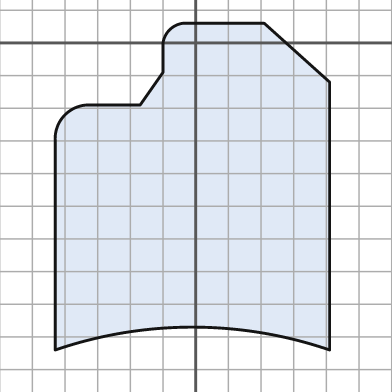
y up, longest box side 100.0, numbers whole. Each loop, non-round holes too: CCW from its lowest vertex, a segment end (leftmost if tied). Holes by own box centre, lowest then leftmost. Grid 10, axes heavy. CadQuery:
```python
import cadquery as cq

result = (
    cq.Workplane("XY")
    .moveTo(-43.0, -94.0)
    .threePointArc((-1.0, -87.0), (41.0, -94.0))
    .lineTo(41.0, -12.0)
    .lineTo(21.0, 6.0)
    .lineTo(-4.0, 6.0)
    .threePointArc((-8.0, 4.0), (-10.0, 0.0))
    .lineTo(-10.0, -9.0)
    .lineTo(-17.0, -19.0)
    .lineTo(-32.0, -19.0)
    .threePointArc((-40.0, -22.0), (-43.0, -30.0))
    .close()
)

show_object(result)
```